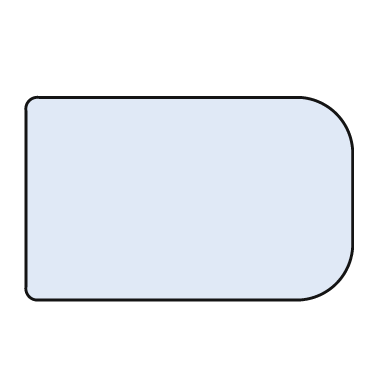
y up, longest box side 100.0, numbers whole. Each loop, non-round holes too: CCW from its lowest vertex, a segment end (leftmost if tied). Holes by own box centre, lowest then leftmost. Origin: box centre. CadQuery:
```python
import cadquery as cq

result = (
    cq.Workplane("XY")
    .moveTo(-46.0, -31.0)
    .lineTo(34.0, -31.0)
    .threePointArc((45.0, -26.0), (50.0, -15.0))
    .lineTo(50.0, 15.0)
    .threePointArc((45.0, 26.0), (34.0, 31.0))
    .lineTo(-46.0, 31.0)
    .threePointArc((-49.0, 30.0), (-50.0, 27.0))
    .lineTo(-50.0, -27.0)
    .threePointArc((-49.0, -30.0), (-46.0, -31.0))
    .close()
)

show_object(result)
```